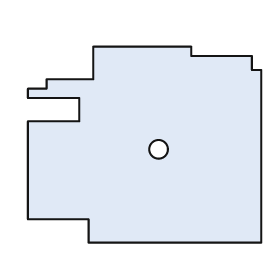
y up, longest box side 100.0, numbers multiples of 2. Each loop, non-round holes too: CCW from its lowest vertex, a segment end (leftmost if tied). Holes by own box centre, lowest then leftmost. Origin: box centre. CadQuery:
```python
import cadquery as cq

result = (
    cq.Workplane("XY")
    .moveTo(-24.0, -42.0)
    .lineTo(50.0, -42.0)
    .lineTo(50.0, 32.0)
    .lineTo(46.0, 32.0)
    .lineTo(46.0, 38.0)
    .lineTo(20.0, 38.0)
    .lineTo(20.0, 42.0)
    .lineTo(-22.0, 42.0)
    .lineTo(-22.0, 28.0)
    .lineTo(-42.0, 28.0)
    .lineTo(-42.0, 24.0)
    .lineTo(-50.0, 24.0)
    .lineTo(-50.0, 20.0)
    .lineTo(-28.0, 20.0)
    .lineTo(-28.0, 10.0)
    .lineTo(-50.0, 10.0)
    .lineTo(-50.0, -32.0)
    .lineTo(-24.0, -32.0)
    .close()
    .moveTo(6.0, -2.0)
    .circle(4.0)
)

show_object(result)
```